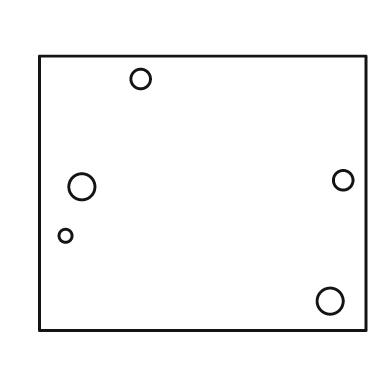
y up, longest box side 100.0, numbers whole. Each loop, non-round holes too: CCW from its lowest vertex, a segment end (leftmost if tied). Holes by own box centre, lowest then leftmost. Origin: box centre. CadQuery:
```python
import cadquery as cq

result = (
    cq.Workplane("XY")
    .moveTo(-50.0, -42.0)
    .lineTo(50.0, -42.0)
    .lineTo(50.0, 42.0)
    .lineTo(-50.0, 42.0)
    .close()
    .moveTo(39.0, -33.0)
    .circle(4.0)
    .moveTo(-42.0, -13.0)
    .circle(2.0)
    .moveTo(-37.0, 2.0)
    .circle(4.0)
    .moveTo(43.0, 4.0)
    .circle(3.0)
    .moveTo(-19.0, 35.0)
    .circle(3.0)
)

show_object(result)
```